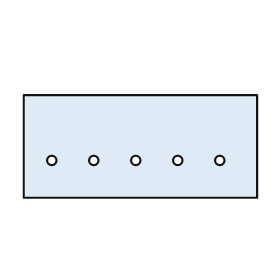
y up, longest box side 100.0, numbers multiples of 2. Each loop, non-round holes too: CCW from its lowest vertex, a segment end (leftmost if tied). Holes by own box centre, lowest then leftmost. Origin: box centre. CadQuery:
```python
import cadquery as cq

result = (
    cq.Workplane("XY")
    .moveTo(-50.0, -22.0)
    .lineTo(50.0, -22.0)
    .lineTo(50.0, 22.0)
    .lineTo(-50.0, 22.0)
    .close()
    .moveTo(-38.0, -6.0)
    .circle(2.0)
    .moveTo(-20.0, -6.0)
    .circle(2.0)
    .moveTo(-2.0, -6.0)
    .circle(2.0)
    .moveTo(16.0, -6.0)
    .circle(2.0)
    .moveTo(34.0, -6.0)
    .circle(2.0)
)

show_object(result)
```